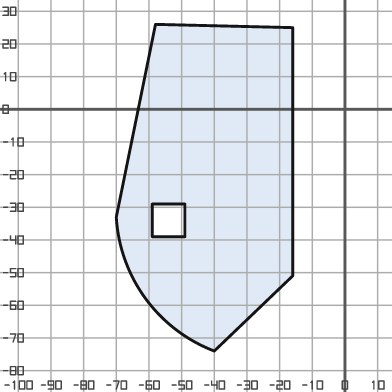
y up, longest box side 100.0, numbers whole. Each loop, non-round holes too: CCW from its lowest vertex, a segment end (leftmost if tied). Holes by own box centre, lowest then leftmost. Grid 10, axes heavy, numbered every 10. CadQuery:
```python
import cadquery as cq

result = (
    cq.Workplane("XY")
    .moveTo(-40.0, -74.0)
    .lineTo(-16.0, -51.0)
    .lineTo(-16.0, 25.0)
    .lineTo(-58.0, 26.0)
    .lineTo(-70.0, -33.0)
    .threePointArc((-61.0, -58.0), (-40.0, -74.0))
    .close()
    .moveTo(-59.0, -39.0)
    .lineTo(-49.0, -39.0)
    .lineTo(-49.0, -29.0)
    .lineTo(-59.0, -29.0)
    .close()
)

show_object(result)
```